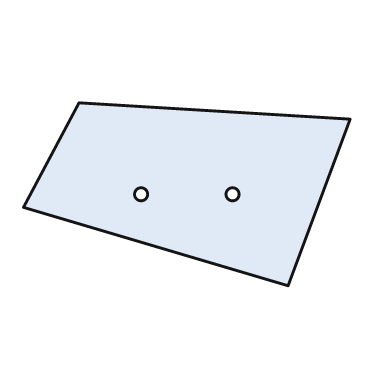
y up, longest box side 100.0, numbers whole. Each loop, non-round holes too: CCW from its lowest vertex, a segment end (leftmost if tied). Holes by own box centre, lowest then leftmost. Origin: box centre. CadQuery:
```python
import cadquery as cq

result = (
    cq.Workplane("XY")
    .moveTo(31.0, -28.0)
    .lineTo(50.0, 23.0)
    .lineTo(-33.0, 28.0)
    .lineTo(-50.0, -4.0)
    .close()
    .moveTo(-14.0, 0.0)
    .circle(2.0)
    .moveTo(14.0, 0.0)
    .circle(2.0)
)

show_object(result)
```